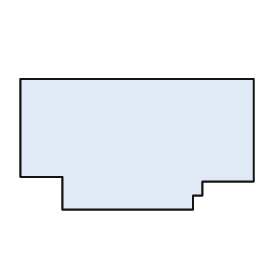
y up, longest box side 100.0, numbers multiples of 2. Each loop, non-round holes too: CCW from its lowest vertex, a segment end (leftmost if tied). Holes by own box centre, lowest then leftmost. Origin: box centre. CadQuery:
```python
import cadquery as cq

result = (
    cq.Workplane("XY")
    .moveTo(-32.0, -28.0)
    .lineTo(24.0, -28.0)
    .lineTo(24.0, -22.0)
    .lineTo(28.0, -22.0)
    .lineTo(28.0, -16.0)
    .lineTo(50.0, -16.0)
    .lineTo(50.0, 28.0)
    .lineTo(-50.0, 28.0)
    .lineTo(-50.0, -14.0)
    .lineTo(-32.0, -14.0)
    .close()
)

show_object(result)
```